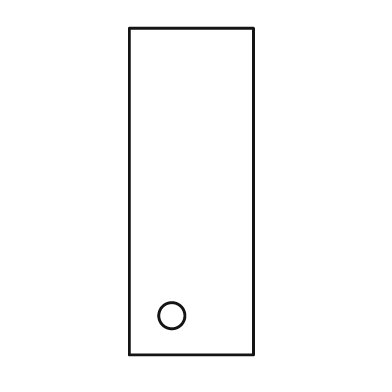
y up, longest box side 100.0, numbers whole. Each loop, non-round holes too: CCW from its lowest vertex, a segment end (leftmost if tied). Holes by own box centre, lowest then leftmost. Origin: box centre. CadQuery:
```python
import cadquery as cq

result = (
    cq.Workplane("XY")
    .moveTo(-19.0, -50.0)
    .lineTo(19.0, -50.0)
    .lineTo(19.0, 50.0)
    .lineTo(-19.0, 50.0)
    .close()
    .moveTo(-6.0, -38.0)
    .circle(4.0)
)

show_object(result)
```